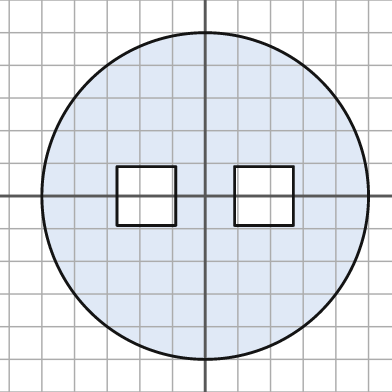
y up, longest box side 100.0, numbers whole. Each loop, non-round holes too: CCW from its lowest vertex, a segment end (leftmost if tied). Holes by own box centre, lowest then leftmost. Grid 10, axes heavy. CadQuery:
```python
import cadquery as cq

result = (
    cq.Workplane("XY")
    .moveTo(0.0, 0.0)
    .circle(50.0)
    .moveTo(-27.0, -9.0)
    .lineTo(-9.0, -9.0)
    .lineTo(-9.0, 9.0)
    .lineTo(-27.0, 9.0)
    .close()
    .moveTo(9.0, -9.0)
    .lineTo(27.0, -9.0)
    .lineTo(27.0, 9.0)
    .lineTo(9.0, 9.0)
    .close()
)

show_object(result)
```